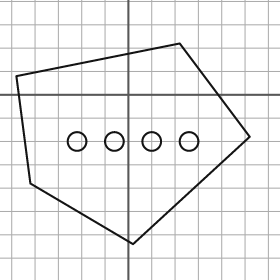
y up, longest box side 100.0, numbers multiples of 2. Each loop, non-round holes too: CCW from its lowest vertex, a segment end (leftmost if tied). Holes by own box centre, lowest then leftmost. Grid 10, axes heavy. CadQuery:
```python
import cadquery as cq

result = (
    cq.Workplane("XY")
    .moveTo(2.0, -64.0)
    .lineTo(52.0, -18.0)
    .lineTo(22.0, 22.0)
    .lineTo(-48.0, 8.0)
    .lineTo(-42.0, -38.0)
    .close()
    .moveTo(-22.0, -20.0)
    .circle(4.0)
    .moveTo(-6.0, -20.0)
    .circle(4.0)
    .moveTo(10.0, -20.0)
    .circle(4.0)
    .moveTo(26.0, -20.0)
    .circle(4.0)
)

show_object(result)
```